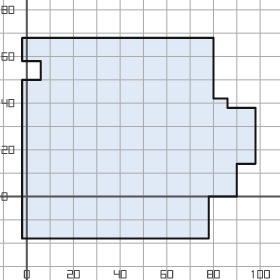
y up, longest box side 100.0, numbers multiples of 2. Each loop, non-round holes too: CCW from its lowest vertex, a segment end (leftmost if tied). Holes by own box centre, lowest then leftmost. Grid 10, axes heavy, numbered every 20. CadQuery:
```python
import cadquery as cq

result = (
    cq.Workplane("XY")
    .moveTo(-2.0, -18.0)
    .lineTo(78.0, -18.0)
    .lineTo(78.0, 0.0)
    .lineTo(90.0, 0.0)
    .lineTo(90.0, 14.0)
    .lineTo(98.0, 14.0)
    .lineTo(98.0, 38.0)
    .lineTo(86.0, 38.0)
    .lineTo(86.0, 42.0)
    .lineTo(80.0, 42.0)
    .lineTo(80.0, 68.0)
    .lineTo(-2.0, 68.0)
    .lineTo(-2.0, 58.0)
    .lineTo(6.0, 58.0)
    .lineTo(6.0, 50.0)
    .lineTo(-2.0, 50.0)
    .close()
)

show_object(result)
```